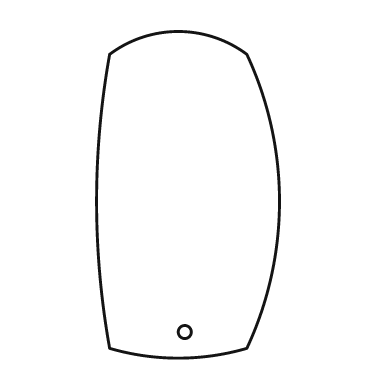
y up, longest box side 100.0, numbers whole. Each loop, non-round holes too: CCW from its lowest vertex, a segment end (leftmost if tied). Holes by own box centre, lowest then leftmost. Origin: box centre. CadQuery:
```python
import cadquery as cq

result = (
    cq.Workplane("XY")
    .moveTo(-24.0, -47.0)
    .threePointArc((-3.0, -50.0), (18.0, -47.0))
    .threePointArc((28.0, -2.0), (18.0, 43.0))
    .threePointArc((-3.0, 50.0), (-24.0, 43.0))
    .threePointArc((-28.0, -2.0), (-24.0, -47.0))
    .close()
    .moveTo(-1.0, -42.0)
    .circle(2.0)
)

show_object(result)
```